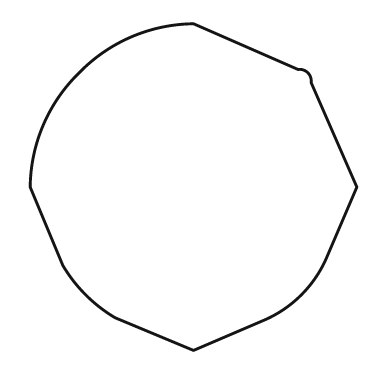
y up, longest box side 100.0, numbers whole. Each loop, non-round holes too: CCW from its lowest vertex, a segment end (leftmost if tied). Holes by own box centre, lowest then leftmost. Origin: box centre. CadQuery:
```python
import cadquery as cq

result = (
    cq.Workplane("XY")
    .moveTo(0.0, -50.0)
    .lineTo(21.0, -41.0)
    .threePointArc((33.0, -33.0), (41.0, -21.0))
    .lineTo(50.0, 0.0)
    .lineTo(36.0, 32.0)
    .threePointArc((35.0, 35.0), (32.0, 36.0))
    .lineTo(0.0, 50.0)
    .threePointArc((-19.0, 46.0), (-35.0, 35.0))
    .threePointArc((-46.0, 19.0), (-50.0, 0.0))
    .lineTo(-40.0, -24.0)
    .threePointArc((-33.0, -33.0), (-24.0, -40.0))
    .close()
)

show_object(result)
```